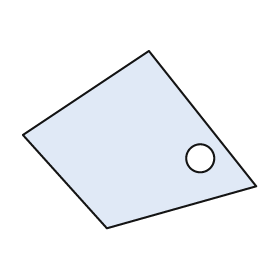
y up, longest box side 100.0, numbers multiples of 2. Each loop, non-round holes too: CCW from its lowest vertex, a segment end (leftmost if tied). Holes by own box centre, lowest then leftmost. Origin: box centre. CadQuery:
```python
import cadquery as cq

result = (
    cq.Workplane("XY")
    .moveTo(-14.0, -38.0)
    .lineTo(50.0, -20.0)
    .lineTo(4.0, 38.0)
    .lineTo(-50.0, 2.0)
    .close()
    .moveTo(26.0, -8.0)
    .circle(6.0)
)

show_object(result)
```